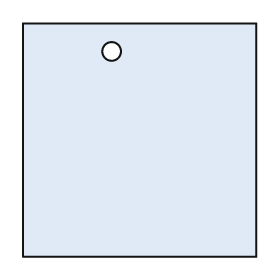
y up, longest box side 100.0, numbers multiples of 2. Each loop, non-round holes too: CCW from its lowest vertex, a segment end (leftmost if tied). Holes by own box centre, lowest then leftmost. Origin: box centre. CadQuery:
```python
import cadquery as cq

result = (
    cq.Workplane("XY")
    .moveTo(-50.0, -50.0)
    .lineTo(50.0, -50.0)
    .lineTo(50.0, 50.0)
    .lineTo(-50.0, 50.0)
    .close()
    .moveTo(-12.0, 38.0)
    .circle(4.0)
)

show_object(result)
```